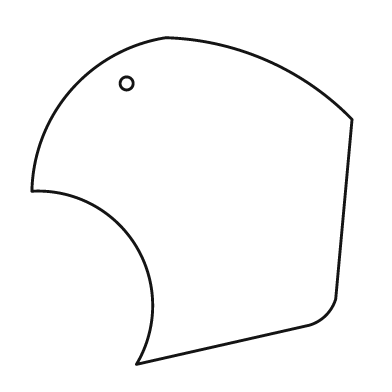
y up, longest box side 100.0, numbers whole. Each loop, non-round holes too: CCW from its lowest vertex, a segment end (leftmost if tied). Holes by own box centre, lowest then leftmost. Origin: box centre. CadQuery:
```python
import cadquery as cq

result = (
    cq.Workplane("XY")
    .moveTo(-17.0, -50.0)
    .lineTo(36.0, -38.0)
    .threePointArc((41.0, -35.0), (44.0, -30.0))
    .lineTo(49.0, 25.0)
    .threePointArc((23.0, 43.0), (-8.0, 50.0))
    .threePointArc((-37.0, 34.0), (-49.0, 3.0))
    .threePointArc((-17.0, -14.0), (-17.0, -50.0))
    .close()
    .moveTo(-20.0, 36.0)
    .circle(2.0)
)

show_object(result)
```